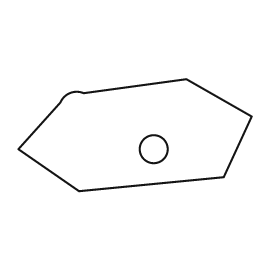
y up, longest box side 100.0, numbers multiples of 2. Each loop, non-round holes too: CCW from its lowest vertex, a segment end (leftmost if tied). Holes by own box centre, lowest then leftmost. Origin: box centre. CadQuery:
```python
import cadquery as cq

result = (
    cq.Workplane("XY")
    .moveTo(-24.0, -24.0)
    .lineTo(38.0, -18.0)
    .lineTo(50.0, 8.0)
    .lineTo(22.0, 24.0)
    .lineTo(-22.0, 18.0)
    .threePointArc((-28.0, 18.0), (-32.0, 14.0))
    .lineTo(-50.0, -6.0)
    .close()
    .moveTo(8.0, -6.0)
    .circle(6.0)
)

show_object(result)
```